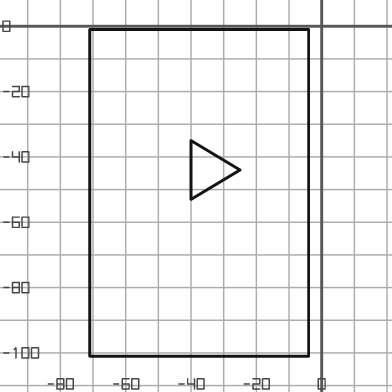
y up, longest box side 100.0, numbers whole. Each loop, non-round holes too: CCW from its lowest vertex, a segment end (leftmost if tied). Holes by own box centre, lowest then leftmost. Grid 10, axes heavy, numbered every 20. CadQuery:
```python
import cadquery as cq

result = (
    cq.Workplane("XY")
    .moveTo(-71.0, -101.0)
    .lineTo(-4.0, -101.0)
    .lineTo(-4.0, -1.0)
    .lineTo(-71.0, -1.0)
    .close()
    .moveTo(-40.0, -53.0)
    .lineTo(-25.0, -44.0)
    .lineTo(-40.0, -35.0)
    .close()
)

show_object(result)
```